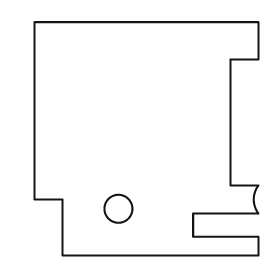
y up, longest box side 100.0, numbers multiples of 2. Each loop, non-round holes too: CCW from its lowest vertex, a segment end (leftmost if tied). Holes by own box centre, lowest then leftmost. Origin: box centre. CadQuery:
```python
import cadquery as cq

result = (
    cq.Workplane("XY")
    .moveTo(-36.0, -50.0)
    .lineTo(48.0, -50.0)
    .lineTo(48.0, -42.0)
    .lineTo(20.0, -42.0)
    .lineTo(20.0, -32.0)
    .lineTo(48.0, -32.0)
    .threePointArc((46.0, -26.0), (48.0, -20.0))
    .lineTo(36.0, -20.0)
    .lineTo(36.0, 34.0)
    .lineTo(48.0, 34.0)
    .lineTo(48.0, 50.0)
    .lineTo(-48.0, 50.0)
    .lineTo(-48.0, -26.0)
    .lineTo(-36.0, -26.0)
    .close()
    .moveTo(-12.0, -30.0)
    .circle(6.0)
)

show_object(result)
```